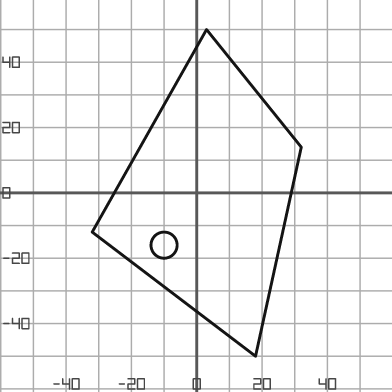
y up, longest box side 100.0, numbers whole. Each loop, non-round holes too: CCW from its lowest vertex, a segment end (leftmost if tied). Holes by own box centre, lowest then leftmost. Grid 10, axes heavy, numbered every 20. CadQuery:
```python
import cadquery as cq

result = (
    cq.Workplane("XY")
    .moveTo(18.0, -50.0)
    .lineTo(32.0, 14.0)
    .lineTo(3.0, 50.0)
    .lineTo(-32.0, -12.0)
    .close()
    .moveTo(-10.0, -16.0)
    .circle(4.0)
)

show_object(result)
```